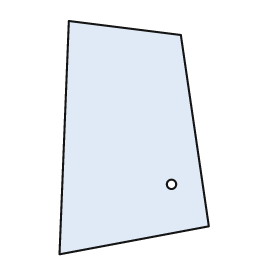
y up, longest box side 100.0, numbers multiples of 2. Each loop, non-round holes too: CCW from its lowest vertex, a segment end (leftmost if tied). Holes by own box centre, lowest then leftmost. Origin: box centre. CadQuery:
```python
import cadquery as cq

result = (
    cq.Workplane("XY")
    .moveTo(-32.0, -50.0)
    .lineTo(32.0, -38.0)
    .lineTo(20.0, 44.0)
    .lineTo(-28.0, 50.0)
    .close()
    .moveTo(16.0, -20.0)
    .circle(2.0)
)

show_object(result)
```